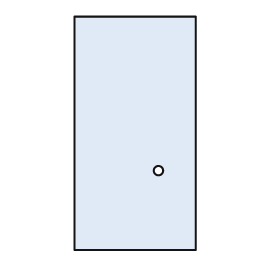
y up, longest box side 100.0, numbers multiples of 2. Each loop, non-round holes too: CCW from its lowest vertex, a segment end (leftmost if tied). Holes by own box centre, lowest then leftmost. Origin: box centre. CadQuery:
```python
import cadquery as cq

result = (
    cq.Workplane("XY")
    .moveTo(-26.0, -50.0)
    .lineTo(26.0, -50.0)
    .lineTo(26.0, 50.0)
    .lineTo(-26.0, 50.0)
    .close()
    .moveTo(10.0, -16.0)
    .circle(2.0)
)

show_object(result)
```